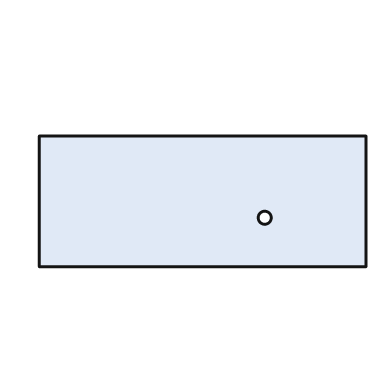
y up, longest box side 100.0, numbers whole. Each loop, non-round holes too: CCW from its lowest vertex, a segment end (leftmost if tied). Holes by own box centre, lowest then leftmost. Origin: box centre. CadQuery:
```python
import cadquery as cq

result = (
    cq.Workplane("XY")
    .moveTo(-50.0, -20.0)
    .lineTo(50.0, -20.0)
    .lineTo(50.0, 20.0)
    .lineTo(-50.0, 20.0)
    .close()
    .moveTo(19.0, -5.0)
    .circle(2.0)
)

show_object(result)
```